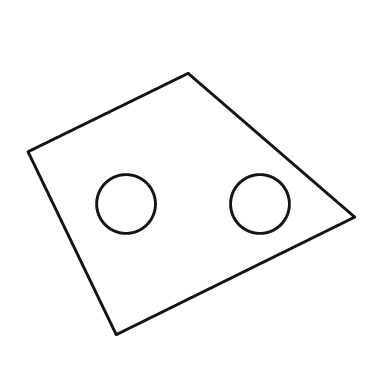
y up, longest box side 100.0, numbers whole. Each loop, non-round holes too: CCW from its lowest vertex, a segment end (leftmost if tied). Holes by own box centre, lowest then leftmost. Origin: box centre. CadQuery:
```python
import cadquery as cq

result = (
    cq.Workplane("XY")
    .moveTo(-23.0, -40.0)
    .lineTo(50.0, -4.0)
    .lineTo(-1.0, 40.0)
    .lineTo(-50.0, 16.0)
    .close()
    .moveTo(-20.0, 0.0)
    .circle(9.0)
    .moveTo(21.0, 0.0)
    .circle(9.0)
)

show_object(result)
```